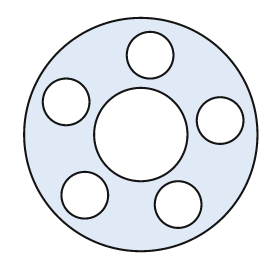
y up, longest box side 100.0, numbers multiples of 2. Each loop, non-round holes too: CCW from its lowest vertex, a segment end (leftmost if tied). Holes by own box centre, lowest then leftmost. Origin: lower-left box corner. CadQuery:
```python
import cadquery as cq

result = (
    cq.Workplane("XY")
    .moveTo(50.0, 50.0)
    .circle(50.0)
    .moveTo(66.0, 20.0)
    .circle(10.0)
    .moveTo(26.0, 24.0)
    .circle(10.0)
    .moveTo(50.0, 50.0)
    .circle(20.0)
    .moveTo(84.0, 56.0)
    .circle(10.0)
    .moveTo(18.0, 64.0)
    .circle(10.0)
    .moveTo(54.0, 84.0)
    .circle(10.0)
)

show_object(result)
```